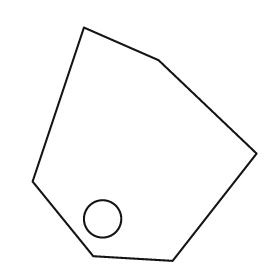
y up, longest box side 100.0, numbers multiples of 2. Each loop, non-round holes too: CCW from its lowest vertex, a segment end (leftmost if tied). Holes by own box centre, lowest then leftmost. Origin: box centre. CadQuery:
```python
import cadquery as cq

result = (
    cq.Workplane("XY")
    .moveTo(12.0, -50.0)
    .lineTo(48.0, -4.0)
    .lineTo(6.0, 36.0)
    .lineTo(-26.0, 50.0)
    .lineTo(-48.0, -16.0)
    .lineTo(-22.0, -48.0)
    .close()
    .moveTo(-18.0, -32.0)
    .circle(8.0)
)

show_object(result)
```